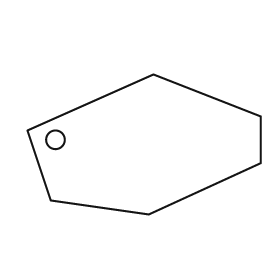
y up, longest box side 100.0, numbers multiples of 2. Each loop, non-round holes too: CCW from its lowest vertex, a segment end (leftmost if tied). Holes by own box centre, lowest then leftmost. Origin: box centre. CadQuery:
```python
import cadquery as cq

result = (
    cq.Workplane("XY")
    .moveTo(2.0, -30.0)
    .lineTo(50.0, -8.0)
    .lineTo(50.0, 12.0)
    .lineTo(4.0, 30.0)
    .lineTo(-50.0, 6.0)
    .lineTo(-40.0, -24.0)
    .close()
    .moveTo(-38.0, 2.0)
    .circle(4.0)
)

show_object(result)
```